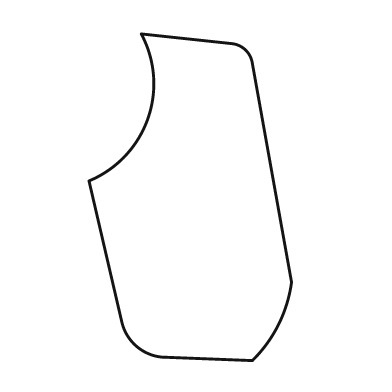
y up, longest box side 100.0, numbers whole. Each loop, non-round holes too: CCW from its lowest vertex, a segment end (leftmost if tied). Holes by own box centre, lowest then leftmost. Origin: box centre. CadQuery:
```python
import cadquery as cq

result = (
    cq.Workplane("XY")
    .moveTo(19.0, -50.0)
    .threePointArc((27.0, -39.0), (31.0, -26.0))
    .lineTo(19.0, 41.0)
    .threePointArc((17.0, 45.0), (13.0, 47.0))
    .lineTo(-15.0, 50.0)
    .threePointArc((-13.0, 24.0), (-31.0, 5.0))
    .lineTo(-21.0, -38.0)
    .threePointArc((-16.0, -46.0), (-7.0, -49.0))
    .close()
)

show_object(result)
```